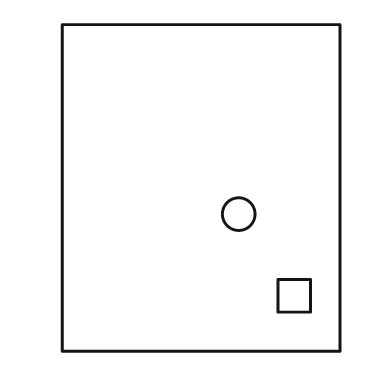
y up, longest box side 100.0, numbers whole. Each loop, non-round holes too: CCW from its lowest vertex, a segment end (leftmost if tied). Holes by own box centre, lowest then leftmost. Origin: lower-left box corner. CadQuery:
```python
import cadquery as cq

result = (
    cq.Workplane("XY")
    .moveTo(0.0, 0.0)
    .lineTo(85.0, 0.0)
    .lineTo(85.0, 100.0)
    .lineTo(0.0, 100.0)
    .close()
    .moveTo(66.0, 12.0)
    .lineTo(76.0, 12.0)
    .lineTo(76.0, 22.0)
    .lineTo(66.0, 22.0)
    .close()
    .moveTo(54.0, 42.0)
    .circle(5.0)
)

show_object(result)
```